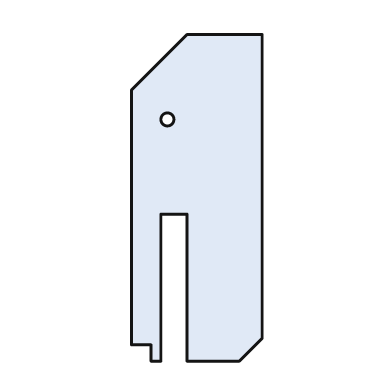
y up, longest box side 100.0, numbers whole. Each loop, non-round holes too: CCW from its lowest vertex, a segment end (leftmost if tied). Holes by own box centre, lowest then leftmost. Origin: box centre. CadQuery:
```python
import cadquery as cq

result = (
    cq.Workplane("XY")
    .moveTo(-14.0, -50.0)
    .lineTo(-11.0, -50.0)
    .lineTo(-11.0, -5.0)
    .lineTo(-3.0, -5.0)
    .lineTo(-3.0, -50.0)
    .lineTo(13.0, -50.0)
    .lineTo(20.0, -43.0)
    .lineTo(20.0, 50.0)
    .lineTo(-3.0, 50.0)
    .lineTo(-20.0, 33.0)
    .lineTo(-20.0, -45.0)
    .lineTo(-14.0, -45.0)
    .close()
    .moveTo(-9.0, 24.0)
    .circle(2.0)
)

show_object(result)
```